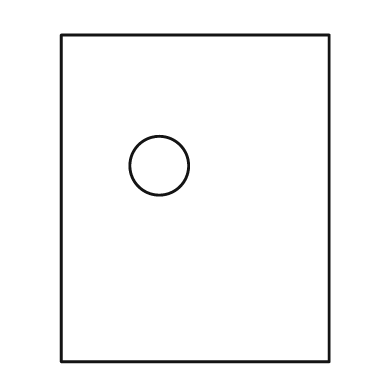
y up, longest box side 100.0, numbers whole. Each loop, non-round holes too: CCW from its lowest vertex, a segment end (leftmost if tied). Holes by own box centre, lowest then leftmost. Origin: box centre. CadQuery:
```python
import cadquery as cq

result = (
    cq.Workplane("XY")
    .moveTo(-41.0, -50.0)
    .lineTo(41.0, -50.0)
    .lineTo(41.0, 50.0)
    .lineTo(-41.0, 50.0)
    .close()
    .moveTo(-11.0, 10.0)
    .circle(9.0)
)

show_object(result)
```